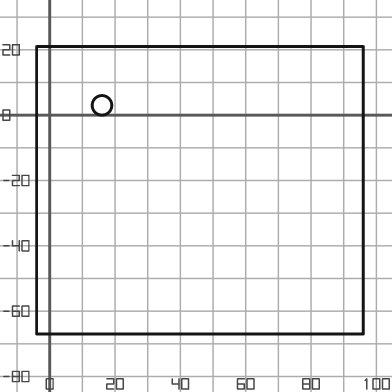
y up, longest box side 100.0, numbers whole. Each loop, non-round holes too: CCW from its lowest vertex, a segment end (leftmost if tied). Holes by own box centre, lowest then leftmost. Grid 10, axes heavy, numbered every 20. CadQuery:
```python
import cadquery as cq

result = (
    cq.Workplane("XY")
    .moveTo(-4.0, -67.0)
    .lineTo(96.0, -67.0)
    .lineTo(96.0, 21.0)
    .lineTo(-4.0, 21.0)
    .close()
    .moveTo(16.0, 3.0)
    .circle(3.0)
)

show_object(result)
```